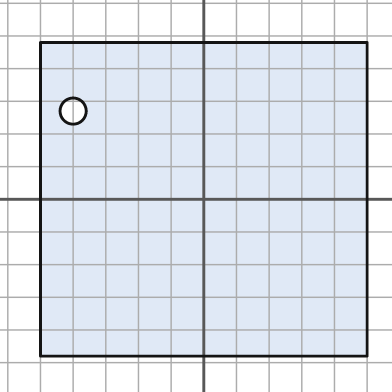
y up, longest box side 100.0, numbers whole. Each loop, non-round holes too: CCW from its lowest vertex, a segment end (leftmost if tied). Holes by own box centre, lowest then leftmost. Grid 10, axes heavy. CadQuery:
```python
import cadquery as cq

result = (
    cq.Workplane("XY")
    .moveTo(-50.0, -48.0)
    .lineTo(50.0, -48.0)
    .lineTo(50.0, 48.0)
    .lineTo(-50.0, 48.0)
    .close()
    .moveTo(-40.0, 27.0)
    .circle(4.0)
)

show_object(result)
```